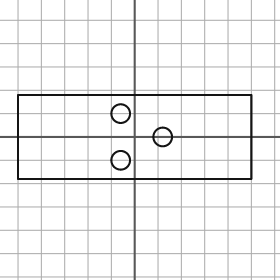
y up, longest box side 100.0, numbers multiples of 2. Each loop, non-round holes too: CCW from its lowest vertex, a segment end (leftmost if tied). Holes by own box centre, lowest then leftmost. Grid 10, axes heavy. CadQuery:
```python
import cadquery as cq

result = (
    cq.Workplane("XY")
    .moveTo(-50.0, -18.0)
    .lineTo(50.0, -18.0)
    .lineTo(50.0, 18.0)
    .lineTo(-50.0, 18.0)
    .close()
    .moveTo(-6.0, -10.0)
    .circle(4.0)
    .moveTo(12.0, 0.0)
    .circle(4.0)
    .moveTo(-6.0, 10.0)
    .circle(4.0)
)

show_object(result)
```